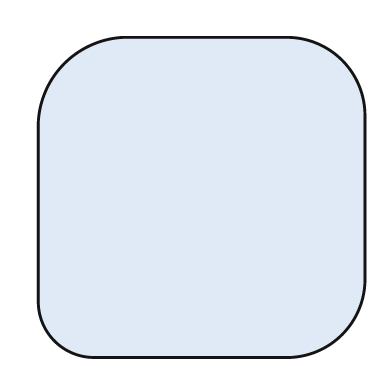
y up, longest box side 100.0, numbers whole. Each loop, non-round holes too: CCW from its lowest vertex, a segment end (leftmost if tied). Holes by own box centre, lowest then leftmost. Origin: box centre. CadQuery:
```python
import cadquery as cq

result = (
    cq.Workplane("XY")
    .moveTo(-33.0, -49.0)
    .lineTo(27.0, -49.0)
    .threePointArc((43.0, -42.0), (50.0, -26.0))
    .lineTo(50.0, 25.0)
    .threePointArc((43.0, 42.0), (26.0, 49.0))
    .lineTo(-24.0, 49.0)
    .threePointArc((-42.0, 41.0), (-50.0, 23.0))
    .lineTo(-50.0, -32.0)
    .threePointArc((-45.0, -44.0), (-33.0, -49.0))
    .close()
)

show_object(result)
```